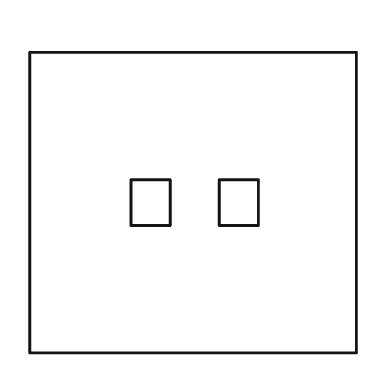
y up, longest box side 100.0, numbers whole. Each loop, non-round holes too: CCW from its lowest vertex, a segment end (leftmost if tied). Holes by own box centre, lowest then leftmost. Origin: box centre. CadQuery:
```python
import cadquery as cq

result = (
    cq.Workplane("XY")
    .moveTo(-50.0, -46.0)
    .lineTo(50.0, -46.0)
    .lineTo(50.0, 46.0)
    .lineTo(-50.0, 46.0)
    .close()
    .moveTo(-19.0, -7.0)
    .lineTo(-7.0, -7.0)
    .lineTo(-7.0, 7.0)
    .lineTo(-19.0, 7.0)
    .close()
    .moveTo(8.0, -7.0)
    .lineTo(20.0, -7.0)
    .lineTo(20.0, 7.0)
    .lineTo(8.0, 7.0)
    .close()
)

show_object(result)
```